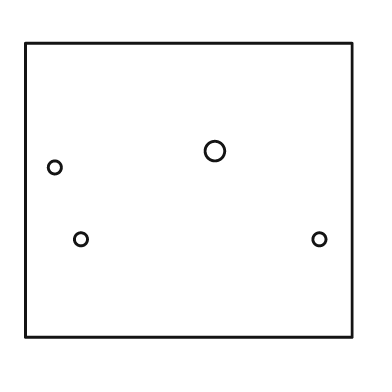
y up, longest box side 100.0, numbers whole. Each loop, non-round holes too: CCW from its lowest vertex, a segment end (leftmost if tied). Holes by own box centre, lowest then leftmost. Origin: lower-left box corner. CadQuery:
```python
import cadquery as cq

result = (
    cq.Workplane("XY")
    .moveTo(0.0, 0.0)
    .lineTo(100.0, 0.0)
    .lineTo(100.0, 90.0)
    .lineTo(0.0, 90.0)
    .close()
    .moveTo(17.0, 30.0)
    .circle(2.0)
    .moveTo(90.0, 30.0)
    .circle(2.0)
    .moveTo(9.0, 52.0)
    .circle(2.0)
    .moveTo(58.0, 57.0)
    .circle(3.0)
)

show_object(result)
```